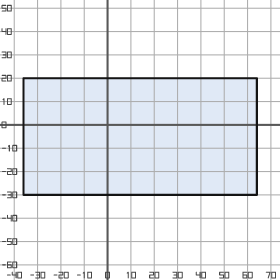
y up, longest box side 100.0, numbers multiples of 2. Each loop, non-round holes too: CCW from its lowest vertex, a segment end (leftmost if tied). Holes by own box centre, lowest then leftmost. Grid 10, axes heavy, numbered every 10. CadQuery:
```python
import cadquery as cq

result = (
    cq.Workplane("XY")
    .moveTo(-36.0, -30.0)
    .lineTo(64.0, -30.0)
    .lineTo(64.0, 20.0)
    .lineTo(-36.0, 20.0)
    .close()
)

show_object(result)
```